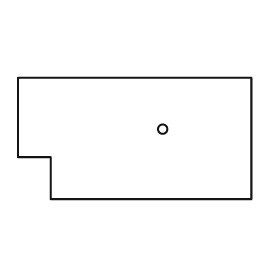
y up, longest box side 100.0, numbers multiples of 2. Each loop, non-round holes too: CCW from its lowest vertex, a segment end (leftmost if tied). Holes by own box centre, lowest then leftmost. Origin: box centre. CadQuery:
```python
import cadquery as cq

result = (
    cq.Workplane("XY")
    .moveTo(-36.0, -26.0)
    .lineTo(50.0, -26.0)
    .lineTo(50.0, 26.0)
    .lineTo(-50.0, 26.0)
    .lineTo(-50.0, -8.0)
    .lineTo(-36.0, -8.0)
    .close()
    .moveTo(12.0, 4.0)
    .circle(2.0)
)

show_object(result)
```